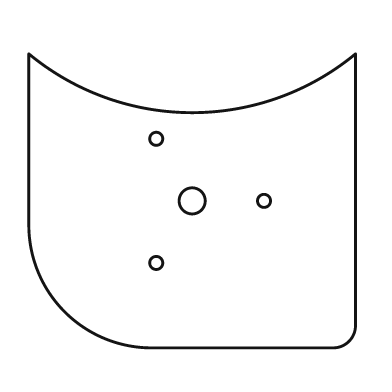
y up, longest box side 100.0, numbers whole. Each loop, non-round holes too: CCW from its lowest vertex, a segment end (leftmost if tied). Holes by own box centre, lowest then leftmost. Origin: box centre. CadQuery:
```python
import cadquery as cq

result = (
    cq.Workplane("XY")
    .moveTo(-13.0, -45.0)
    .lineTo(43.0, -45.0)
    .threePointArc((48.0, -43.0), (50.0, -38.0))
    .lineTo(50.0, 45.0)
    .threePointArc((0.0, 27.0), (-50.0, 45.0))
    .lineTo(-50.0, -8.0)
    .threePointArc((-39.0, -34.0), (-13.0, -45.0))
    .close()
    .moveTo(-11.0, -19.0)
    .circle(2.0)
    .moveTo(0.0, 0.0)
    .circle(4.0)
    .moveTo(22.0, 0.0)
    .circle(2.0)
    .moveTo(-11.0, 19.0)
    .circle(2.0)
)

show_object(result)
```